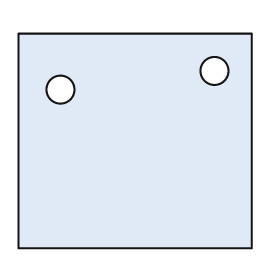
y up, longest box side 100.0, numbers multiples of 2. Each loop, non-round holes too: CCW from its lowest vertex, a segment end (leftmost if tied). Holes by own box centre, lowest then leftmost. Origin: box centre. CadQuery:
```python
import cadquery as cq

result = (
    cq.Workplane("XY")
    .moveTo(-50.0, -46.0)
    .lineTo(50.0, -46.0)
    .lineTo(50.0, 46.0)
    .lineTo(-50.0, 46.0)
    .close()
    .moveTo(-32.0, 22.0)
    .circle(6.0)
    .moveTo(34.0, 30.0)
    .circle(6.0)
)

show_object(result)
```